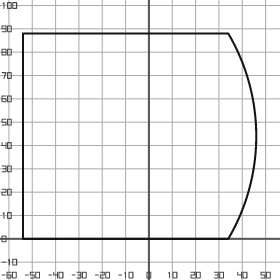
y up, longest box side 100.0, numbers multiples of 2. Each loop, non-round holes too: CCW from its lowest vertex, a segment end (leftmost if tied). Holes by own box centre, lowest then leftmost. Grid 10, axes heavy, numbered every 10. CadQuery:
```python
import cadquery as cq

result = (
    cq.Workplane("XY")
    .moveTo(-54.0, 0.0)
    .lineTo(34.0, 0.0)
    .threePointArc((46.0, 44.0), (34.0, 88.0))
    .lineTo(-54.0, 88.0)
    .close()
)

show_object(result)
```